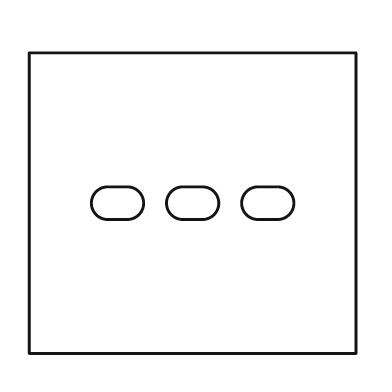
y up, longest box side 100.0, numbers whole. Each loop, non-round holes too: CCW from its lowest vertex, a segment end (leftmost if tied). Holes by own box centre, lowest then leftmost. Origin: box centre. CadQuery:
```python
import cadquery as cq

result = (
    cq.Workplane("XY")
    .moveTo(-50.0, -46.0)
    .lineTo(50.0, -46.0)
    .lineTo(50.0, 46.0)
    .lineTo(-50.0, 46.0)
    .close()
    .moveTo(-26.0, -5.0)
    .lineTo(-20.0, -5.0)
    .threePointArc((-15.0, 0.0), (-20.0, 5.0))
    .lineTo(-26.0, 5.0)
    .threePointArc((-31.0, 0.0), (-26.0, -5.0))
    .close()
    .moveTo(-3.0, -5.0)
    .lineTo(3.0, -5.0)
    .threePointArc((8.0, 0.0), (3.0, 5.0))
    .lineTo(-3.0, 5.0)
    .threePointArc((-8.0, 0.0), (-3.0, -5.0))
    .close()
    .moveTo(20.0, -5.0)
    .lineTo(26.0, -5.0)
    .threePointArc((31.0, 0.0), (26.0, 5.0))
    .lineTo(20.0, 5.0)
    .threePointArc((15.0, 0.0), (20.0, -5.0))
    .close()
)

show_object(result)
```